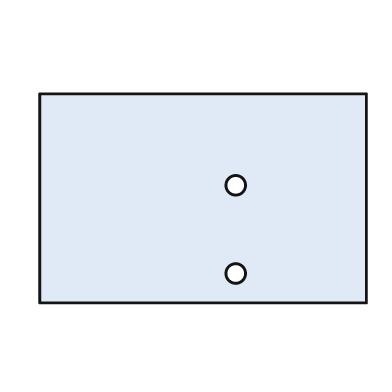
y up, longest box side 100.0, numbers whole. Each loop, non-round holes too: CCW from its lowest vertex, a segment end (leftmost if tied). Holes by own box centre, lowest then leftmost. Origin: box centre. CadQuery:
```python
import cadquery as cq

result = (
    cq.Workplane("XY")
    .moveTo(-50.0, -32.0)
    .lineTo(50.0, -32.0)
    .lineTo(50.0, 32.0)
    .lineTo(-50.0, 32.0)
    .close()
    .moveTo(10.0, -23.0)
    .circle(3.0)
    .moveTo(10.0, 4.0)
    .circle(3.0)
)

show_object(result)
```